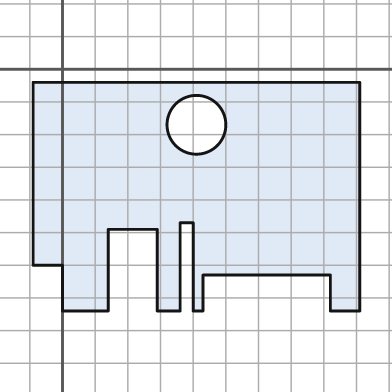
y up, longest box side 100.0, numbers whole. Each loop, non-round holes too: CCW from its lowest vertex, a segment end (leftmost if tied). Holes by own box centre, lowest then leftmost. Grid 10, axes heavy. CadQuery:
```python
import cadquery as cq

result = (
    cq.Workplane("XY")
    .moveTo(0.0, -74.0)
    .lineTo(14.0, -74.0)
    .lineTo(14.0, -49.0)
    .lineTo(29.0, -49.0)
    .lineTo(29.0, -74.0)
    .lineTo(36.0, -74.0)
    .lineTo(36.0, -47.0)
    .lineTo(40.0, -47.0)
    .lineTo(40.0, -74.0)
    .lineTo(43.0, -74.0)
    .lineTo(43.0, -63.0)
    .lineTo(82.0, -63.0)
    .lineTo(82.0, -74.0)
    .lineTo(91.0, -74.0)
    .lineTo(91.0, -4.0)
    .lineTo(-9.0, -4.0)
    .lineTo(-9.0, -60.0)
    .lineTo(0.0, -60.0)
    .close()
    .moveTo(41.0, -17.0)
    .circle(9.0)
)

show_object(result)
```